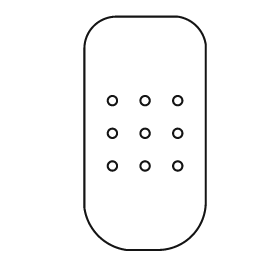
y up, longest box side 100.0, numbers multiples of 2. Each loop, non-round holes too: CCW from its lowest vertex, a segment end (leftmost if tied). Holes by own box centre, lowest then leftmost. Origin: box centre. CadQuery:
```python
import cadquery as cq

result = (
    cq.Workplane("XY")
    .moveTo(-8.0, -50.0)
    .lineTo(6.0, -50.0)
    .threePointArc((20.0, -44.0), (26.0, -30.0))
    .lineTo(26.0, 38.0)
    .threePointArc((22.0, 46.0), (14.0, 50.0))
    .lineTo(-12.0, 50.0)
    .threePointArc((-22.0, 46.0), (-26.0, 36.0))
    .lineTo(-26.0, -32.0)
    .threePointArc((-20.0, -44.0), (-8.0, -50.0))
    .close()
    .moveTo(-14.0, -14.0)
    .circle(2.0)
    .moveTo(0.0, -14.0)
    .circle(2.0)
    .moveTo(14.0, -14.0)
    .circle(2.0)
    .moveTo(-14.0, 0.0)
    .circle(2.0)
    .moveTo(0.0, 0.0)
    .circle(2.0)
    .moveTo(14.0, 0.0)
    .circle(2.0)
    .moveTo(-14.0, 14.0)
    .circle(2.0)
    .moveTo(0.0, 14.0)
    .circle(2.0)
    .moveTo(14.0, 14.0)
    .circle(2.0)
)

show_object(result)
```